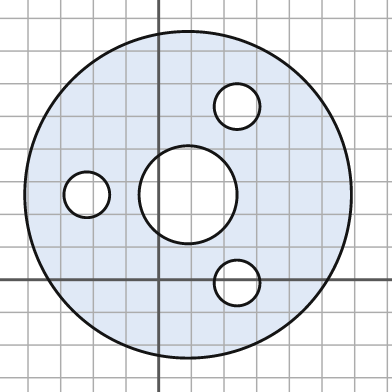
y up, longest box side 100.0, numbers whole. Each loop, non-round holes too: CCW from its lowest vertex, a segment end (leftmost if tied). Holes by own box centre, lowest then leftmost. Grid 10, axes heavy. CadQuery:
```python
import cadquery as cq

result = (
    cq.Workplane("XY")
    .moveTo(9.0, 26.0)
    .circle(50.0)
    .moveTo(24.0, -1.0)
    .circle(7.0)
    .moveTo(-22.0, 26.0)
    .circle(7.0)
    .moveTo(9.0, 26.0)
    .circle(15.0)
    .moveTo(24.0, 53.0)
    .circle(7.0)
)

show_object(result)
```